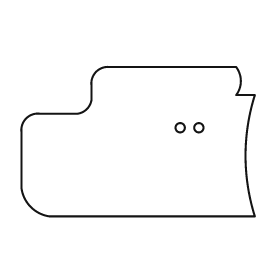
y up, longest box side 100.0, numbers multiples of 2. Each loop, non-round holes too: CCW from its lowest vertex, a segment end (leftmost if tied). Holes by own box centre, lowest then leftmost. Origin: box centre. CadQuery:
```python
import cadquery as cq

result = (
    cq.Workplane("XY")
    .moveTo(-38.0, -32.0)
    .lineTo(50.0, -32.0)
    .threePointArc((46.0, -6.0), (50.0, 20.0))
    .lineTo(42.0, 20.0)
    .threePointArc((44.0, 26.0), (42.0, 32.0))
    .lineTo(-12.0, 32.0)
    .threePointArc((-18.0, 30.0), (-20.0, 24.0))
    .lineTo(-20.0, 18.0)
    .threePointArc((-22.0, 14.0), (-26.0, 12.0))
    .lineTo(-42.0, 12.0)
    .threePointArc((-48.0, 10.0), (-50.0, 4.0))
    .lineTo(-50.0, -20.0)
    .threePointArc((-46.0, -28.0), (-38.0, -32.0))
    .close()
    .moveTo(18.0, 6.0)
    .circle(2.0)
    .moveTo(26.0, 6.0)
    .circle(2.0)
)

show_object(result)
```